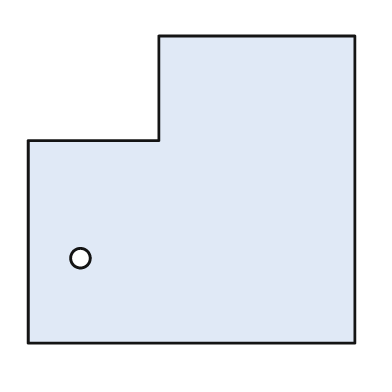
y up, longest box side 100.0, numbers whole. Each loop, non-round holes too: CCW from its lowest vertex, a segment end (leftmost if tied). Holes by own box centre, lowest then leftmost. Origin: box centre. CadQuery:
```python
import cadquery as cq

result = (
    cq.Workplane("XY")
    .moveTo(-50.0, -47.0)
    .lineTo(50.0, -47.0)
    .lineTo(50.0, 47.0)
    .lineTo(-10.0, 47.0)
    .lineTo(-10.0, 15.0)
    .lineTo(-50.0, 15.0)
    .close()
    .moveTo(-34.0, -21.0)
    .circle(3.0)
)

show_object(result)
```